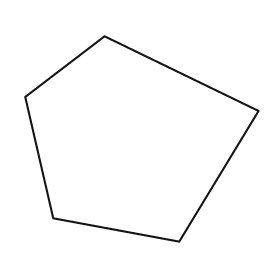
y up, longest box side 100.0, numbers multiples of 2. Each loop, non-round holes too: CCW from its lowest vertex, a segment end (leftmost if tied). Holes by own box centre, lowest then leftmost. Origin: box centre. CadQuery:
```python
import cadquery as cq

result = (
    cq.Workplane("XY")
    .moveTo(16.0, -44.0)
    .lineTo(50.0, 12.0)
    .lineTo(-16.0, 44.0)
    .lineTo(-50.0, 18.0)
    .lineTo(-38.0, -34.0)
    .close()
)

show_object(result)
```